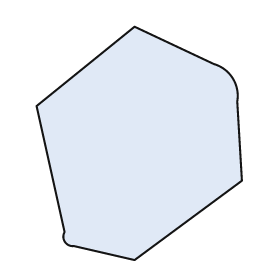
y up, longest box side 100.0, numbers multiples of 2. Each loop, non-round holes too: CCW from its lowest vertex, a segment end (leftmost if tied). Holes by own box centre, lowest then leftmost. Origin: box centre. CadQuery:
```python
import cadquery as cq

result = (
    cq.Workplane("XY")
    .moveTo(-2.0, -50.0)
    .lineTo(44.0, -16.0)
    .lineTo(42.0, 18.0)
    .threePointArc((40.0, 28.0), (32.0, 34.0))
    .lineTo(-2.0, 50.0)
    .lineTo(-44.0, 16.0)
    .lineTo(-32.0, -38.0)
    .threePointArc((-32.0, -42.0), (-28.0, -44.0))
    .close()
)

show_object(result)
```